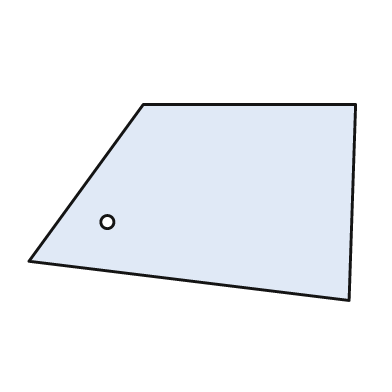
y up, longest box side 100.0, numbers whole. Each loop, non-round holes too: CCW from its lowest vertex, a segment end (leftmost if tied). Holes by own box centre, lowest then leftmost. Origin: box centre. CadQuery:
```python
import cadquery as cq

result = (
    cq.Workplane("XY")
    .moveTo(48.0, -30.0)
    .lineTo(50.0, 30.0)
    .lineTo(-15.0, 30.0)
    .lineTo(-50.0, -18.0)
    .close()
    .moveTo(-26.0, -6.0)
    .circle(2.0)
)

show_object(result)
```